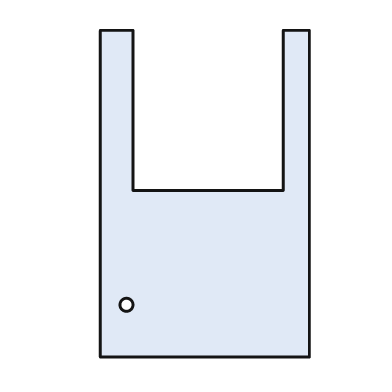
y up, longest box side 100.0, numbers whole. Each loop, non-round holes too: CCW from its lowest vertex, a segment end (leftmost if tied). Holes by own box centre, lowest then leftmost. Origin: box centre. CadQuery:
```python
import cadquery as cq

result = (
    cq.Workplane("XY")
    .moveTo(-32.0, -50.0)
    .lineTo(32.0, -50.0)
    .lineTo(32.0, 50.0)
    .lineTo(24.0, 50.0)
    .lineTo(24.0, 1.0)
    .lineTo(-22.0, 1.0)
    .lineTo(-22.0, 50.0)
    .lineTo(-32.0, 50.0)
    .close()
    .moveTo(-24.0, -34.0)
    .circle(2.0)
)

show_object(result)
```